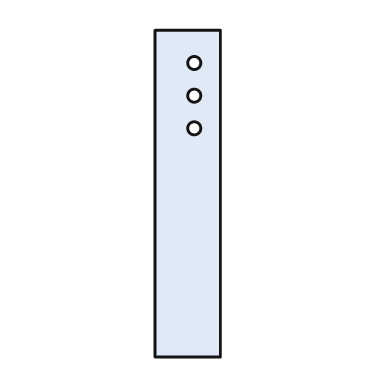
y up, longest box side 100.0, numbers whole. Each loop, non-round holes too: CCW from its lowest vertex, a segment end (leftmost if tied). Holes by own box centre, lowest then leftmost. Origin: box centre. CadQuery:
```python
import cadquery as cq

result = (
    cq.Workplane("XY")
    .moveTo(-10.0, -50.0)
    .lineTo(10.0, -50.0)
    .lineTo(10.0, 50.0)
    .lineTo(-10.0, 50.0)
    .close()
    .moveTo(2.0, 20.0)
    .circle(2.0)
    .moveTo(2.0, 30.0)
    .circle(2.0)
    .moveTo(2.0, 40.0)
    .circle(2.0)
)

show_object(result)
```